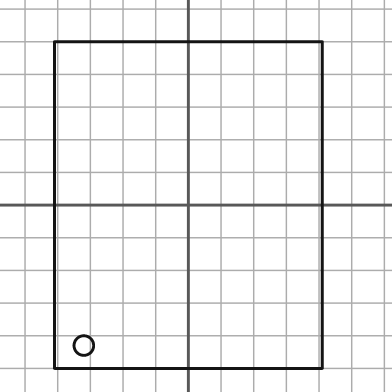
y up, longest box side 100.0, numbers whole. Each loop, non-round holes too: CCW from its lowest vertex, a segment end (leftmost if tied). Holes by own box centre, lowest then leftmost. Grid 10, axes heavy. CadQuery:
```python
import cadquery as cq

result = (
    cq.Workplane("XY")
    .moveTo(-41.0, -50.0)
    .lineTo(41.0, -50.0)
    .lineTo(41.0, 50.0)
    .lineTo(-41.0, 50.0)
    .close()
    .moveTo(-32.0, -43.0)
    .circle(3.0)
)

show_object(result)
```